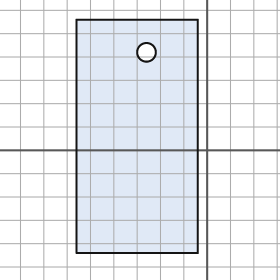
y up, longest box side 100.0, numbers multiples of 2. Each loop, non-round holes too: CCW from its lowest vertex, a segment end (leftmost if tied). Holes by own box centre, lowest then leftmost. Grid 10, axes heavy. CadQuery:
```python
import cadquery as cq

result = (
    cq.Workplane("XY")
    .moveTo(-56.0, -44.0)
    .lineTo(-4.0, -44.0)
    .lineTo(-4.0, 56.0)
    .lineTo(-56.0, 56.0)
    .close()
    .moveTo(-26.0, 42.0)
    .circle(4.0)
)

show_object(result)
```